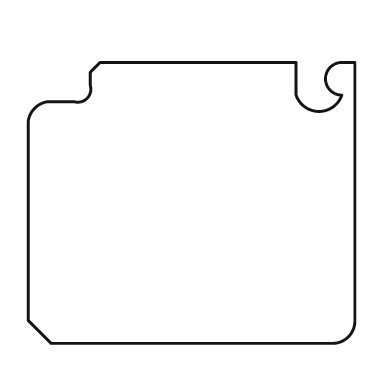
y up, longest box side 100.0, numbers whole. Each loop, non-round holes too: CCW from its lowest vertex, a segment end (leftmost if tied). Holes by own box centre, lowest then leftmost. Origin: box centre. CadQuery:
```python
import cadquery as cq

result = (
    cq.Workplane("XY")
    .moveTo(-43.0, -43.0)
    .lineTo(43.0, -43.0)
    .threePointArc((48.0, -41.0), (50.0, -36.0))
    .lineTo(50.0, 43.0)
    .lineTo(46.0, 43.0)
    .threePointArc((41.0, 38.0), (46.0, 33.0))
    .threePointArc((39.0, 28.0), (32.0, 33.0))
    .lineTo(32.0, 43.0)
    .lineTo(-28.0, 43.0)
    .lineTo(-31.0, 40.0)
    .lineTo(-31.0, 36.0)
    .threePointArc((-32.0, 32.0), (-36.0, 31.0))
    .lineTo(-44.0, 31.0)
    .threePointArc((-48.0, 29.0), (-50.0, 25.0))
    .lineTo(-50.0, -36.0)
    .close()
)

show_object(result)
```